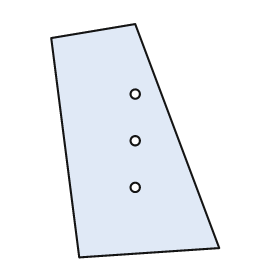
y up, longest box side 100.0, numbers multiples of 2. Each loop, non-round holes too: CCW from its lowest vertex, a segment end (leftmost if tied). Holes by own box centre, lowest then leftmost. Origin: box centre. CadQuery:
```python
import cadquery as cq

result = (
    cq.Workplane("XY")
    .moveTo(-24.0, -50.0)
    .lineTo(36.0, -46.0)
    .lineTo(0.0, 50.0)
    .lineTo(-36.0, 44.0)
    .close()
    .moveTo(0.0, -20.0)
    .circle(2.0)
    .moveTo(0.0, 0.0)
    .circle(2.0)
    .moveTo(0.0, 20.0)
    .circle(2.0)
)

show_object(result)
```